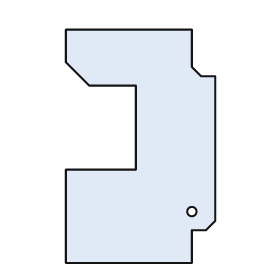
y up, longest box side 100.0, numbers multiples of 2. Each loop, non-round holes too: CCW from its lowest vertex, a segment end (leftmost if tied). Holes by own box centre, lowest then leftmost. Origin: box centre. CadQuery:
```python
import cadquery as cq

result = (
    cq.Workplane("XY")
    .moveTo(-32.0, -50.0)
    .lineTo(22.0, -50.0)
    .lineTo(22.0, -36.0)
    .lineTo(28.0, -36.0)
    .lineTo(32.0, -32.0)
    .lineTo(32.0, 30.0)
    .lineTo(26.0, 30.0)
    .lineTo(22.0, 34.0)
    .lineTo(22.0, 50.0)
    .lineTo(-32.0, 50.0)
    .lineTo(-32.0, 36.0)
    .lineTo(-22.0, 26.0)
    .lineTo(-2.0, 26.0)
    .lineTo(-2.0, -10.0)
    .lineTo(-32.0, -10.0)
    .close()
    .moveTo(22.0, -28.0)
    .circle(2.0)
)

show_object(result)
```